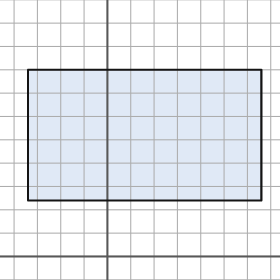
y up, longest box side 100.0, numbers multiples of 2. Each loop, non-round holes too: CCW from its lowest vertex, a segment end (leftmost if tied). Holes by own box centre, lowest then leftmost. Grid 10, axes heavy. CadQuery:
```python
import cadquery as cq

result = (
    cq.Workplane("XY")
    .moveTo(-34.0, 24.0)
    .lineTo(66.0, 24.0)
    .lineTo(66.0, 80.0)
    .lineTo(-34.0, 80.0)
    .close()
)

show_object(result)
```